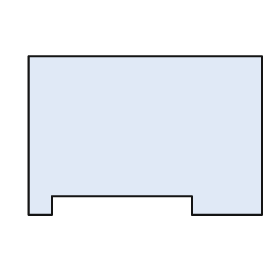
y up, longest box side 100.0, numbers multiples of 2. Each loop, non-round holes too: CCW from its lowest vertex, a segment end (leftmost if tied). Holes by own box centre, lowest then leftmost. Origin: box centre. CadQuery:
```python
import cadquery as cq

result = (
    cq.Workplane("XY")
    .moveTo(-50.0, -34.0)
    .lineTo(-40.0, -34.0)
    .lineTo(-40.0, -26.0)
    .lineTo(20.0, -26.0)
    .lineTo(20.0, -34.0)
    .lineTo(50.0, -34.0)
    .lineTo(50.0, 34.0)
    .lineTo(-50.0, 34.0)
    .close()
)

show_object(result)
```